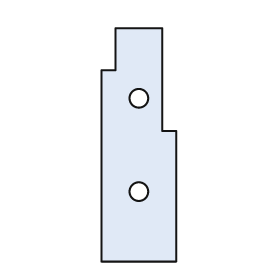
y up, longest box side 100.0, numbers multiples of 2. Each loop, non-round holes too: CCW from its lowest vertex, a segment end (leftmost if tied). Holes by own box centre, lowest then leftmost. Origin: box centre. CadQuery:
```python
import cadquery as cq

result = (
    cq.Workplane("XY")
    .moveTo(-16.0, -50.0)
    .lineTo(16.0, -50.0)
    .lineTo(16.0, 6.0)
    .lineTo(10.0, 6.0)
    .lineTo(10.0, 50.0)
    .lineTo(-10.0, 50.0)
    .lineTo(-10.0, 32.0)
    .lineTo(-16.0, 32.0)
    .close()
    .moveTo(0.0, -20.0)
    .circle(4.0)
    .moveTo(0.0, 20.0)
    .circle(4.0)
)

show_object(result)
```